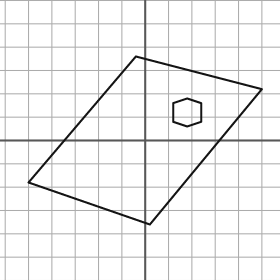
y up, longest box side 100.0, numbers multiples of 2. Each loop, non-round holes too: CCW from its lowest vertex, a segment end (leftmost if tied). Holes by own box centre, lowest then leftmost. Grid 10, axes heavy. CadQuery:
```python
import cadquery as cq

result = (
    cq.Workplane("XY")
    .moveTo(2.0, -36.0)
    .lineTo(50.0, 22.0)
    .lineTo(-4.0, 36.0)
    .lineTo(-50.0, -18.0)
    .close()
    .moveTo(18.0, 6.0)
    .lineTo(24.0, 8.0)
    .lineTo(24.0, 16.0)
    .lineTo(18.0, 18.0)
    .lineTo(12.0, 16.0)
    .lineTo(12.0, 8.0)
    .close()
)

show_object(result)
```